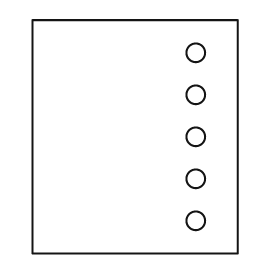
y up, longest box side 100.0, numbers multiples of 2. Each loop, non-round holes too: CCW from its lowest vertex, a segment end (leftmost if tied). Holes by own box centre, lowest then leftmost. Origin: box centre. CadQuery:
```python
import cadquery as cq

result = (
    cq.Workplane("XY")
    .moveTo(-44.0, -50.0)
    .lineTo(44.0, -50.0)
    .lineTo(44.0, 50.0)
    .lineTo(-44.0, 50.0)
    .close()
    .moveTo(26.0, -36.0)
    .circle(4.0)
    .moveTo(26.0, -18.0)
    .circle(4.0)
    .moveTo(26.0, 0.0)
    .circle(4.0)
    .moveTo(26.0, 18.0)
    .circle(4.0)
    .moveTo(26.0, 36.0)
    .circle(4.0)
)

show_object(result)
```